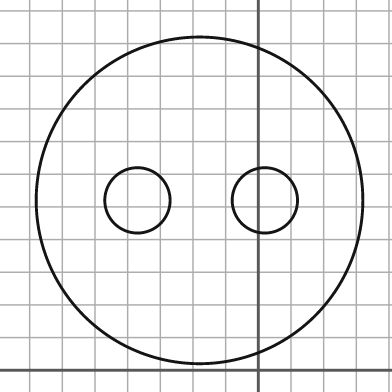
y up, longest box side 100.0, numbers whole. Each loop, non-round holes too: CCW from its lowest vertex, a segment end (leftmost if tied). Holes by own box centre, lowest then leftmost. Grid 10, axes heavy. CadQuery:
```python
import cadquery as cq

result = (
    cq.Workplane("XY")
    .moveTo(-18.0, 52.0)
    .circle(50.0)
    .moveTo(-37.0, 52.0)
    .circle(10.0)
    .moveTo(2.0, 52.0)
    .circle(10.0)
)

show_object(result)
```